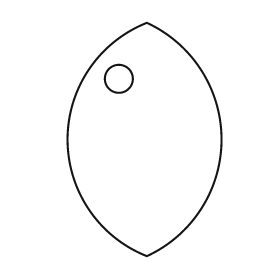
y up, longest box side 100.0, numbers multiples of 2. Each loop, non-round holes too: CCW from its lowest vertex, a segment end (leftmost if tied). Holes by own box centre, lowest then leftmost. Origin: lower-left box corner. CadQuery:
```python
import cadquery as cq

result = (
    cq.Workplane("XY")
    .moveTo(34.0, 0.0)
    .threePointArc((66.0, 50.0), (34.0, 100.0))
    .threePointArc((0.0, 50.0), (34.0, 0.0))
    .close()
    .moveTo(22.0, 76.0)
    .circle(6.0)
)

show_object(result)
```